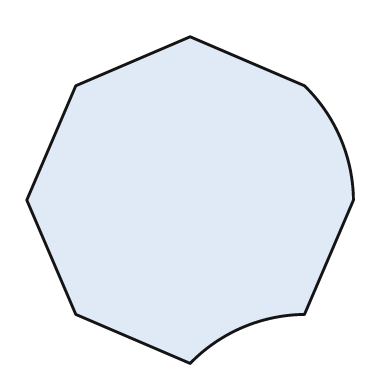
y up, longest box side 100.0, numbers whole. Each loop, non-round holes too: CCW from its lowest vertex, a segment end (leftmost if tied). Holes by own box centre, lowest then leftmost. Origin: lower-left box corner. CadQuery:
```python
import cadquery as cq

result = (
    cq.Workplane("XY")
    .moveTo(50.0, 0.0)
    .threePointArc((66.0, 11.0), (85.0, 15.0))
    .lineTo(100.0, 50.0)
    .threePointArc((96.0, 69.0), (85.0, 85.0))
    .lineTo(50.0, 100.0)
    .lineTo(15.0, 85.0)
    .lineTo(0.0, 50.0)
    .lineTo(15.0, 15.0)
    .close()
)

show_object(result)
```